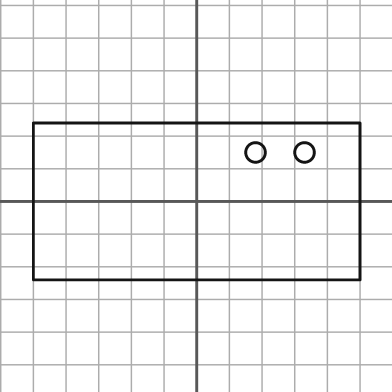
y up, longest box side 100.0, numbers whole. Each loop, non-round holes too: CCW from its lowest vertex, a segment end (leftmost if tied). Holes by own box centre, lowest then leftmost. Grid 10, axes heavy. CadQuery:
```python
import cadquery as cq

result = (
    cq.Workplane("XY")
    .moveTo(-50.0, -24.0)
    .lineTo(50.0, -24.0)
    .lineTo(50.0, 24.0)
    .lineTo(-50.0, 24.0)
    .close()
    .moveTo(18.0, 15.0)
    .circle(3.0)
    .moveTo(33.0, 15.0)
    .circle(3.0)
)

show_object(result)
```